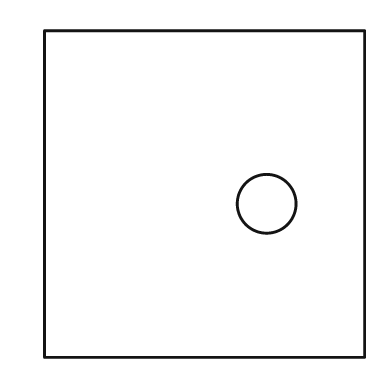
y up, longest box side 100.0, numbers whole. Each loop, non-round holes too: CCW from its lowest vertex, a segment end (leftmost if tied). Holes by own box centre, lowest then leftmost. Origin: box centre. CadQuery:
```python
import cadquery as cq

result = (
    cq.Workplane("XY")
    .moveTo(-49.0, -50.0)
    .lineTo(49.0, -50.0)
    .lineTo(49.0, 50.0)
    .lineTo(-49.0, 50.0)
    .close()
    .moveTo(19.0, -3.0)
    .circle(9.0)
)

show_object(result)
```